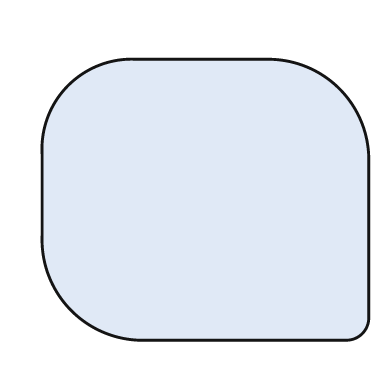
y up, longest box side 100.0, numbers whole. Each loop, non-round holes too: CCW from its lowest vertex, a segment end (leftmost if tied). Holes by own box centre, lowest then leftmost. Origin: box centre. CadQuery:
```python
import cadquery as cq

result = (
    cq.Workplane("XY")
    .moveTo(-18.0, -43.0)
    .lineTo(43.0, -43.0)
    .threePointArc((48.0, -41.0), (50.0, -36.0))
    .lineTo(50.0, 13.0)
    .threePointArc((41.0, 34.0), (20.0, 43.0))
    .lineTo(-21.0, 43.0)
    .threePointArc((-42.0, 35.0), (-50.0, 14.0))
    .lineTo(-50.0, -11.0)
    .threePointArc((-41.0, -34.0), (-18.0, -43.0))
    .close()
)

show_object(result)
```